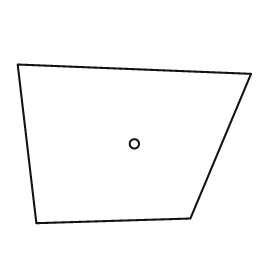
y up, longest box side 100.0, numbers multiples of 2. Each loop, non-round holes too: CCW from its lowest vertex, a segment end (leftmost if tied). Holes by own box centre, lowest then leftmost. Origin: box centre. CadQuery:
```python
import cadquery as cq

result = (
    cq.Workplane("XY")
    .moveTo(-42.0, -34.0)
    .lineTo(24.0, -32.0)
    .lineTo(50.0, 30.0)
    .lineTo(-50.0, 34.0)
    .close()
    .moveTo(0.0, 0.0)
    .circle(2.0)
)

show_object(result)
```